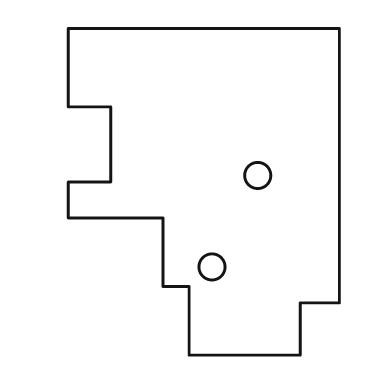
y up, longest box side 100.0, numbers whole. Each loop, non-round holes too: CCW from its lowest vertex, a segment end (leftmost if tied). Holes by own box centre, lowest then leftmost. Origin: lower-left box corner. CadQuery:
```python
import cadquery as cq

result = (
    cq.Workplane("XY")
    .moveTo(37.0, 0.0)
    .lineTo(71.0, 0.0)
    .lineTo(71.0, 16.0)
    .lineTo(83.0, 16.0)
    .lineTo(83.0, 100.0)
    .lineTo(0.0, 100.0)
    .lineTo(0.0, 76.0)
    .lineTo(13.0, 76.0)
    .lineTo(13.0, 53.0)
    .lineTo(0.0, 53.0)
    .lineTo(0.0, 42.0)
    .lineTo(29.0, 42.0)
    .lineTo(29.0, 21.0)
    .lineTo(37.0, 21.0)
    .close()
    .moveTo(44.0, 27.0)
    .circle(4.0)
    .moveTo(58.0, 55.0)
    .circle(4.0)
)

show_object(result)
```